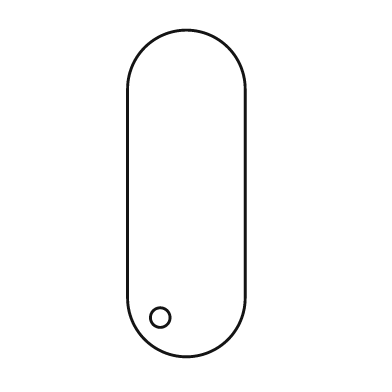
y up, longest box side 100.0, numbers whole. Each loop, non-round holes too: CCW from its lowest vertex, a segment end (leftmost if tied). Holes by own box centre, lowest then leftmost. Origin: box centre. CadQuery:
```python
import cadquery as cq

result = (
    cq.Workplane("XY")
    .moveTo(-18.0, -32.0)
    .threePointArc((0.0, -50.0), (18.0, -32.0))
    .lineTo(18.0, 32.0)
    .threePointArc((0.0, 50.0), (-18.0, 32.0))
    .close()
    .moveTo(-8.0, -38.0)
    .circle(3.0)
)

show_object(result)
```